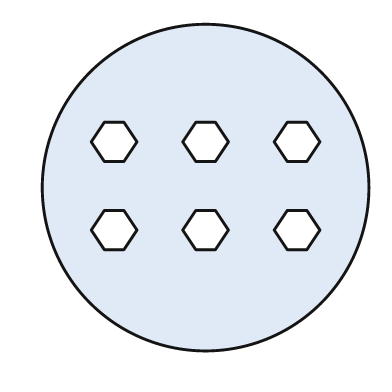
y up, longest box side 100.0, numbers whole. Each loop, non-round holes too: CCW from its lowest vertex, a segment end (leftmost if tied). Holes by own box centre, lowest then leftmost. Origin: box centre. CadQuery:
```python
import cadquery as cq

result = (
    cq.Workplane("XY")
    .moveTo(0.0, 0.0)
    .circle(50.0)
    .moveTo(-31.0, -19.0)
    .lineTo(-25.0, -19.0)
    .lineTo(-21.0, -13.0)
    .lineTo(-25.0, -7.0)
    .lineTo(-31.0, -7.0)
    .lineTo(-35.0, -13.0)
    .close()
    .moveTo(-3.0, -19.0)
    .lineTo(3.0, -19.0)
    .lineTo(7.0, -13.0)
    .lineTo(3.0, -7.0)
    .lineTo(-3.0, -7.0)
    .lineTo(-7.0, -13.0)
    .close()
    .moveTo(25.0, -19.0)
    .lineTo(31.0, -19.0)
    .lineTo(35.0, -13.0)
    .lineTo(31.0, -7.0)
    .lineTo(25.0, -7.0)
    .lineTo(21.0, -13.0)
    .close()
    .moveTo(-31.0, 8.0)
    .lineTo(-25.0, 8.0)
    .lineTo(-21.0, 14.0)
    .lineTo(-25.0, 20.0)
    .lineTo(-31.0, 20.0)
    .lineTo(-35.0, 14.0)
    .close()
    .moveTo(-3.0, 8.0)
    .lineTo(3.0, 8.0)
    .lineTo(7.0, 14.0)
    .lineTo(3.0, 20.0)
    .lineTo(-3.0, 20.0)
    .lineTo(-7.0, 14.0)
    .close()
    .moveTo(25.0, 8.0)
    .lineTo(31.0, 8.0)
    .lineTo(35.0, 14.0)
    .lineTo(31.0, 20.0)
    .lineTo(25.0, 20.0)
    .lineTo(21.0, 14.0)
    .close()
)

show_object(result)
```